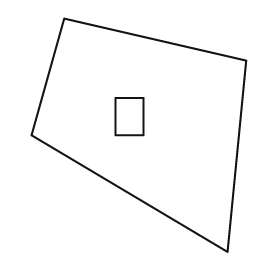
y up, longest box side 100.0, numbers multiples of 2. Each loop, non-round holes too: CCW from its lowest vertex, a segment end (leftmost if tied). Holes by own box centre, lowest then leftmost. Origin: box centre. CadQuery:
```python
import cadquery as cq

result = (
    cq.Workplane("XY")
    .moveTo(38.0, -50.0)
    .lineTo(46.0, 32.0)
    .lineTo(-32.0, 50.0)
    .lineTo(-46.0, 0.0)
    .close()
    .moveTo(-10.0, 0.0)
    .lineTo(2.0, 0.0)
    .lineTo(2.0, 16.0)
    .lineTo(-10.0, 16.0)
    .close()
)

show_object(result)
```